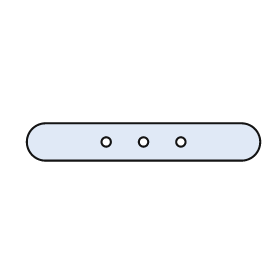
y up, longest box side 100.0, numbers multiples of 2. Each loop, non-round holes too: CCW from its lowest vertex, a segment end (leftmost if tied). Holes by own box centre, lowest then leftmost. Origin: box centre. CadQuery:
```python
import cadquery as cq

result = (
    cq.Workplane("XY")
    .moveTo(-42.0, -8.0)
    .lineTo(42.0, -8.0)
    .threePointArc((50.0, 0.0), (42.0, 8.0))
    .lineTo(-42.0, 8.0)
    .threePointArc((-50.0, 0.0), (-42.0, -8.0))
    .close()
    .moveTo(-16.0, 0.0)
    .circle(2.0)
    .moveTo(0.0, 0.0)
    .circle(2.0)
    .moveTo(16.0, 0.0)
    .circle(2.0)
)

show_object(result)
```